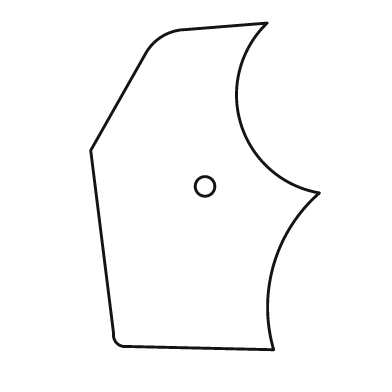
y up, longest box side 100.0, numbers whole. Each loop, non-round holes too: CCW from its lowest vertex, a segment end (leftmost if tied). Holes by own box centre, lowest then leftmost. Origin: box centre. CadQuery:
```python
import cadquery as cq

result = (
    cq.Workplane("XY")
    .moveTo(21.0, -50.0)
    .threePointArc((21.0, -24.0), (35.0, -2.0))
    .threePointArc((11.0, 19.0), (19.0, 50.0))
    .lineTo(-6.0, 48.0)
    .threePointArc((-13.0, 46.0), (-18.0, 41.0))
    .lineTo(-35.0, 11.0)
    .lineTo(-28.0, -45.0)
    .threePointArc((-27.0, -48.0), (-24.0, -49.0))
    .close()
    .moveTo(0.0, 0.0)
    .circle(3.0)
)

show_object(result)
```